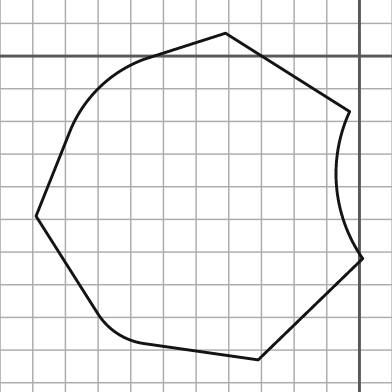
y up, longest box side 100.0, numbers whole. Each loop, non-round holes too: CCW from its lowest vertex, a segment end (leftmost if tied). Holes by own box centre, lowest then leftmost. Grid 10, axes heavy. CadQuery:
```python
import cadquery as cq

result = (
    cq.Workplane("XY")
    .moveTo(-31.0, -93.0)
    .lineTo(1.0, -62.0)
    .threePointArc((-7.0, -40.0), (-3.0, -17.0))
    .lineTo(-41.0, 7.0)
    .lineTo(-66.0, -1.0)
    .threePointArc((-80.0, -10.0), (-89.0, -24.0))
    .lineTo(-99.0, -49.0)
    .lineTo(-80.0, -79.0)
    .threePointArc((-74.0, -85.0), (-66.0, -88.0))
    .close()
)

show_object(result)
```